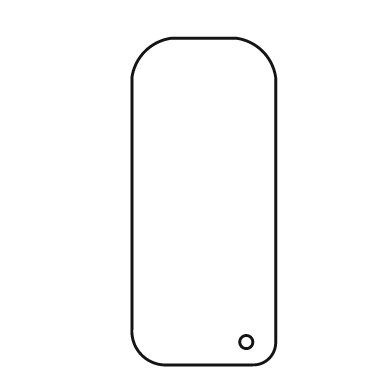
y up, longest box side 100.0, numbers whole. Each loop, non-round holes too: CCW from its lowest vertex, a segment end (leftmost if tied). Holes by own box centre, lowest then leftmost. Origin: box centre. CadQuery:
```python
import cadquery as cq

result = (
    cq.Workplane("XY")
    .moveTo(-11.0, -50.0)
    .lineTo(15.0, -50.0)
    .threePointArc((20.0, -48.0), (22.0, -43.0))
    .lineTo(22.0, 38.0)
    .threePointArc((18.0, 46.0), (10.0, 50.0))
    .lineTo(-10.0, 50.0)
    .threePointArc((-18.0, 46.0), (-22.0, 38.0))
    .lineTo(-22.0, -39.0)
    .threePointArc((-19.0, -47.0), (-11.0, -50.0))
    .close()
    .moveTo(13.0, -43.0)
    .circle(2.0)
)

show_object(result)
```